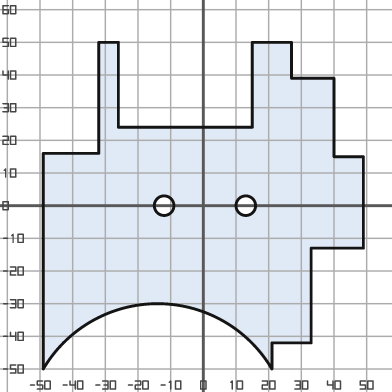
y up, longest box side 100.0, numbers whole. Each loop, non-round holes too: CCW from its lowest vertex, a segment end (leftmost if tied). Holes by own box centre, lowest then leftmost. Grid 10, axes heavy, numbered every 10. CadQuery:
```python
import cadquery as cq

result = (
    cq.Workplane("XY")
    .moveTo(-49.0, -50.0)
    .threePointArc((-14.0, -30.0), (21.0, -50.0))
    .lineTo(21.0, -42.0)
    .lineTo(33.0, -42.0)
    .lineTo(33.0, -13.0)
    .lineTo(49.0, -13.0)
    .lineTo(49.0, 15.0)
    .lineTo(40.0, 15.0)
    .lineTo(40.0, 39.0)
    .lineTo(27.0, 39.0)
    .lineTo(27.0, 50.0)
    .lineTo(15.0, 50.0)
    .lineTo(15.0, 24.0)
    .lineTo(-26.0, 24.0)
    .lineTo(-26.0, 50.0)
    .lineTo(-32.0, 50.0)
    .lineTo(-32.0, 16.0)
    .lineTo(-49.0, 16.0)
    .close()
    .moveTo(-12.0, 0.0)
    .circle(3.0)
    .moveTo(13.0, 0.0)
    .circle(3.0)
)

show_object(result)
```